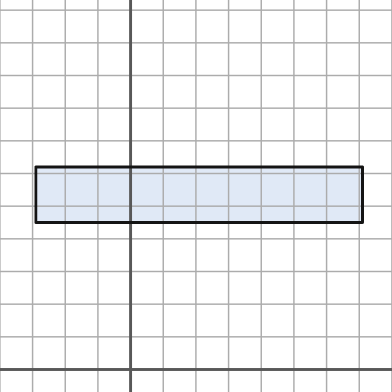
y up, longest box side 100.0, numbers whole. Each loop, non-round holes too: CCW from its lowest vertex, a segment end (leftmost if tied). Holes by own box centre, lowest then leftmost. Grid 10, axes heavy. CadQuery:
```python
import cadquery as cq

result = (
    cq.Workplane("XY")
    .moveTo(-29.0, 45.0)
    .lineTo(71.0, 45.0)
    .lineTo(71.0, 62.0)
    .lineTo(-29.0, 62.0)
    .close()
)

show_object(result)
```